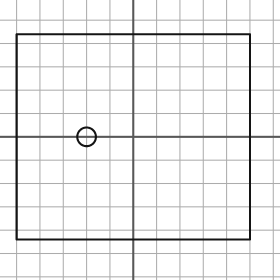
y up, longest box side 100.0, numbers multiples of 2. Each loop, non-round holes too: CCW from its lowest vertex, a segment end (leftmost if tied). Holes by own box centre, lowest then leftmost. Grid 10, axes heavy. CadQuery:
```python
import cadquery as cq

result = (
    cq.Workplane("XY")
    .moveTo(-50.0, -44.0)
    .lineTo(50.0, -44.0)
    .lineTo(50.0, 44.0)
    .lineTo(-50.0, 44.0)
    .close()
    .moveTo(-20.0, 0.0)
    .circle(4.0)
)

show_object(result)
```